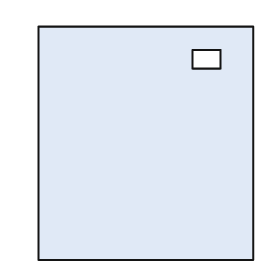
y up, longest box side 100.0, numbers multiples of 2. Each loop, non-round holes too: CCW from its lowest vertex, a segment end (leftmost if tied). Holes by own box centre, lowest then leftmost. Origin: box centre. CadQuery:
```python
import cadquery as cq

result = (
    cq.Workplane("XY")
    .moveTo(-46.0, -50.0)
    .lineTo(46.0, -50.0)
    .lineTo(46.0, 50.0)
    .lineTo(-46.0, 50.0)
    .close()
    .moveTo(20.0, 32.0)
    .lineTo(32.0, 32.0)
    .lineTo(32.0, 40.0)
    .lineTo(20.0, 40.0)
    .close()
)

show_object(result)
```